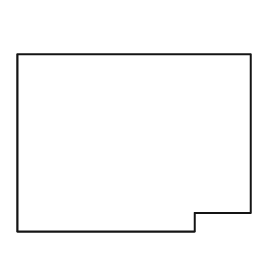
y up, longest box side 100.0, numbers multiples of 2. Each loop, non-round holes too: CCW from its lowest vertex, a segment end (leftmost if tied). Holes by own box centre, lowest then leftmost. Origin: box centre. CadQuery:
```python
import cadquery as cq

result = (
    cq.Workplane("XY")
    .moveTo(-50.0, -38.0)
    .lineTo(26.0, -38.0)
    .lineTo(26.0, -30.0)
    .lineTo(50.0, -30.0)
    .lineTo(50.0, 38.0)
    .lineTo(-50.0, 38.0)
    .close()
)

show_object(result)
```